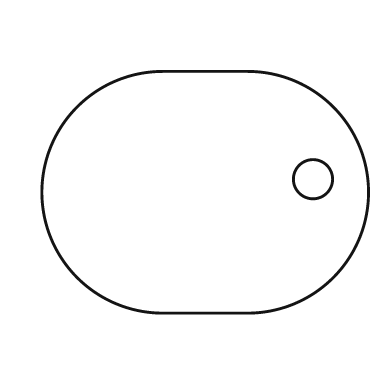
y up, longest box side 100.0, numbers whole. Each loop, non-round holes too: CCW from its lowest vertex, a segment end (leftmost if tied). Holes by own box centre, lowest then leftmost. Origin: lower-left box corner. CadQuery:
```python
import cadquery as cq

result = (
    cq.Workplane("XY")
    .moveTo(37.0, 0.0)
    .lineTo(63.0, 0.0)
    .threePointArc((100.0, 37.0), (63.0, 74.0))
    .lineTo(37.0, 74.0)
    .threePointArc((0.0, 37.0), (37.0, 0.0))
    .close()
    .moveTo(83.0, 41.0)
    .circle(6.0)
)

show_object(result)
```